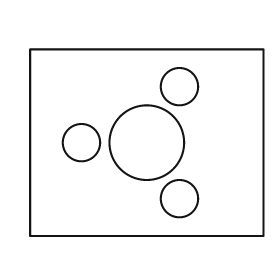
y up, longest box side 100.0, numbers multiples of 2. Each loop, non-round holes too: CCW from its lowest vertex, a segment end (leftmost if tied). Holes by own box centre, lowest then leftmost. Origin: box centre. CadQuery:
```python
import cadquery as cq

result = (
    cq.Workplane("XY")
    .moveTo(-50.0, -40.0)
    .lineTo(50.0, -40.0)
    .lineTo(50.0, 40.0)
    .lineTo(-50.0, 40.0)
    .close()
    .moveTo(14.0, -24.0)
    .circle(8.0)
    .moveTo(-28.0, 0.0)
    .circle(8.0)
    .moveTo(0.0, 0.0)
    .circle(16.0)
    .moveTo(14.0, 24.0)
    .circle(8.0)
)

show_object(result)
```